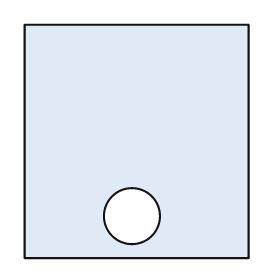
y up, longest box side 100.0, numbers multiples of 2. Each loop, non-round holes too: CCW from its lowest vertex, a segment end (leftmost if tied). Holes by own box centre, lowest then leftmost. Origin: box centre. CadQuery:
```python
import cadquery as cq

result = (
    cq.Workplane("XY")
    .moveTo(-48.0, -50.0)
    .lineTo(48.0, -50.0)
    .lineTo(48.0, 50.0)
    .lineTo(-48.0, 50.0)
    .close()
    .moveTo(-2.0, -32.0)
    .circle(12.0)
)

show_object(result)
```